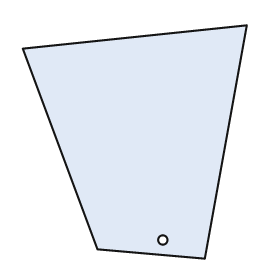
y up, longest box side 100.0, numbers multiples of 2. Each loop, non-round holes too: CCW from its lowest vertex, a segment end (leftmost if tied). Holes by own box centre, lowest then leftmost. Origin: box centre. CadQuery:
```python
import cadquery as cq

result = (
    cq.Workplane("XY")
    .moveTo(30.0, -50.0)
    .lineTo(48.0, 50.0)
    .lineTo(-48.0, 40.0)
    .lineTo(-16.0, -46.0)
    .close()
    .moveTo(12.0, -42.0)
    .circle(2.0)
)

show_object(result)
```